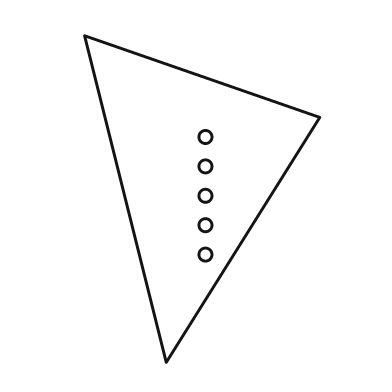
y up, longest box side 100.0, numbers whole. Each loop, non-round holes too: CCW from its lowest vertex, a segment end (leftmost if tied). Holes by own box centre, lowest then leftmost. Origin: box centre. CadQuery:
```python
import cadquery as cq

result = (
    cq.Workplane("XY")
    .moveTo(-11.0, -50.0)
    .lineTo(36.0, 25.0)
    .lineTo(-36.0, 50.0)
    .close()
    .moveTo(1.0, -17.0)
    .circle(2.0)
    .moveTo(1.0, -8.0)
    .circle(2.0)
    .moveTo(1.0, 1.0)
    .circle(2.0)
    .moveTo(1.0, 10.0)
    .circle(2.0)
    .moveTo(1.0, 19.0)
    .circle(2.0)
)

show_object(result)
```